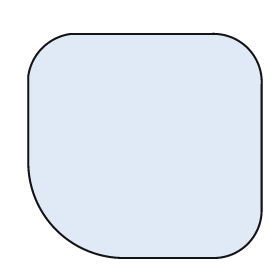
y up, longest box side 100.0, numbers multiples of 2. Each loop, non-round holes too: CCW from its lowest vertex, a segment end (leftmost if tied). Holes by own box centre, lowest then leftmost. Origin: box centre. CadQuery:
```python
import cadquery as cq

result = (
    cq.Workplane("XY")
    .moveTo(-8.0, -48.0)
    .lineTo(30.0, -48.0)
    .threePointArc((44.0, -42.0), (50.0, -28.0))
    .lineTo(50.0, 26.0)
    .threePointArc((44.0, 42.0), (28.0, 48.0))
    .lineTo(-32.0, 48.0)
    .threePointArc((-44.0, 42.0), (-50.0, 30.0))
    .lineTo(-50.0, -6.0)
    .threePointArc((-38.0, -36.0), (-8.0, -48.0))
    .close()
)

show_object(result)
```